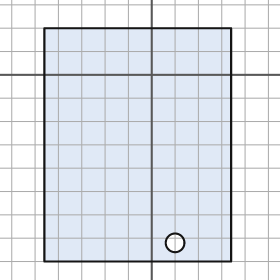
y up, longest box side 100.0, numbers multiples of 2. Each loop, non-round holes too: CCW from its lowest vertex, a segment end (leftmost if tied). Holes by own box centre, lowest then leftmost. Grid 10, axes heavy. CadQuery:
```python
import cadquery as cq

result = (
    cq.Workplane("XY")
    .moveTo(-46.0, -80.0)
    .lineTo(34.0, -80.0)
    .lineTo(34.0, 20.0)
    .lineTo(-46.0, 20.0)
    .close()
    .moveTo(10.0, -72.0)
    .circle(4.0)
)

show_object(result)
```